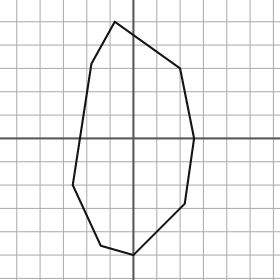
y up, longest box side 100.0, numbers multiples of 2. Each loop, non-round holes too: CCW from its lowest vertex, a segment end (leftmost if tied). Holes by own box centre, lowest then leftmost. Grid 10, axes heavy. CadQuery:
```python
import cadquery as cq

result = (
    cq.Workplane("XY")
    .moveTo(0.0, -50.0)
    .lineTo(22.0, -28.0)
    .lineTo(26.0, 0.0)
    .lineTo(20.0, 30.0)
    .lineTo(-8.0, 50.0)
    .lineTo(-18.0, 32.0)
    .lineTo(-26.0, -20.0)
    .lineTo(-14.0, -46.0)
    .close()
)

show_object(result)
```